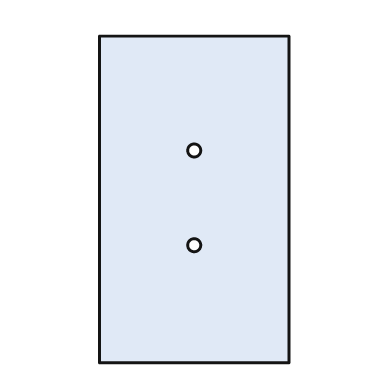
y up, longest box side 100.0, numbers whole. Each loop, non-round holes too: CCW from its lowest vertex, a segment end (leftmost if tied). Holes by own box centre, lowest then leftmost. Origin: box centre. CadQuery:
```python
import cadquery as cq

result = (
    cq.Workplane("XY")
    .moveTo(-29.0, -50.0)
    .lineTo(29.0, -50.0)
    .lineTo(29.0, 50.0)
    .lineTo(-29.0, 50.0)
    .close()
    .moveTo(0.0, -14.0)
    .circle(2.0)
    .moveTo(0.0, 15.0)
    .circle(2.0)
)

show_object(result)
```